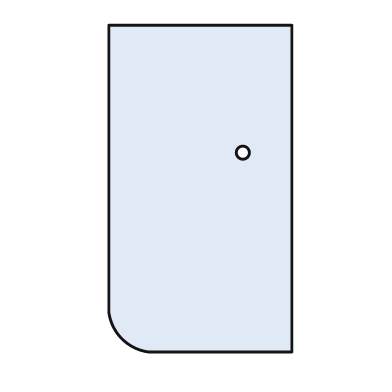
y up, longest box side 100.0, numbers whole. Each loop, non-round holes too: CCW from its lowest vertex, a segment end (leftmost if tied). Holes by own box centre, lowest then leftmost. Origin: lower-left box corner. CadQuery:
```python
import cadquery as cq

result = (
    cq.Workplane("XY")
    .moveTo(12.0, 0.0)
    .lineTo(56.0, 0.0)
    .lineTo(56.0, 100.0)
    .lineTo(0.0, 100.0)
    .lineTo(0.0, 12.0)
    .threePointArc((4.0, 4.0), (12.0, 0.0))
    .close()
    .moveTo(41.0, 61.0)
    .circle(2.0)
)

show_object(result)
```